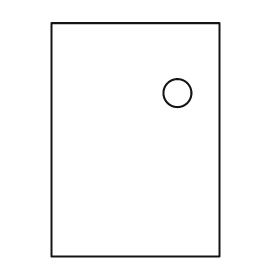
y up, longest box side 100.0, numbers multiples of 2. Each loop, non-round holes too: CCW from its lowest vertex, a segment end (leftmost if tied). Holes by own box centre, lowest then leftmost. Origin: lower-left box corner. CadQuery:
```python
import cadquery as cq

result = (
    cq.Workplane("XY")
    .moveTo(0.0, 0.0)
    .lineTo(72.0, 0.0)
    .lineTo(72.0, 100.0)
    .lineTo(0.0, 100.0)
    .close()
    .moveTo(54.0, 70.0)
    .circle(6.0)
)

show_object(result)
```